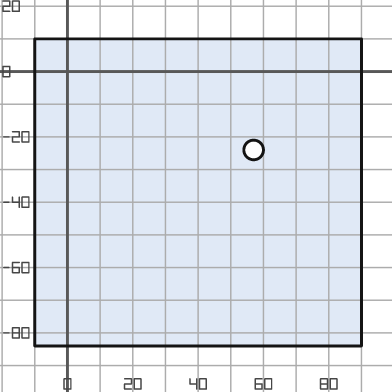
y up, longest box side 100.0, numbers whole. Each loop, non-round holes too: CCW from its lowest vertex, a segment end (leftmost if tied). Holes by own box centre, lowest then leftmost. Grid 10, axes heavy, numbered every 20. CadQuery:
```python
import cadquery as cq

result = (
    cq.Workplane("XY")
    .moveTo(-10.0, -84.0)
    .lineTo(90.0, -84.0)
    .lineTo(90.0, 10.0)
    .lineTo(-10.0, 10.0)
    .close()
    .moveTo(57.0, -24.0)
    .circle(3.0)
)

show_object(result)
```